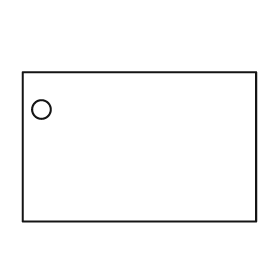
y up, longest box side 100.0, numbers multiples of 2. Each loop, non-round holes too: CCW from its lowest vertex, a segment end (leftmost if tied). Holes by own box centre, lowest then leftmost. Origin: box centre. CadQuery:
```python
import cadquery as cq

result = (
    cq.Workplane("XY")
    .moveTo(-50.0, -32.0)
    .lineTo(50.0, -32.0)
    .lineTo(50.0, 32.0)
    .lineTo(-50.0, 32.0)
    .close()
    .moveTo(-42.0, 16.0)
    .circle(4.0)
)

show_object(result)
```